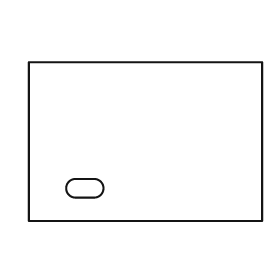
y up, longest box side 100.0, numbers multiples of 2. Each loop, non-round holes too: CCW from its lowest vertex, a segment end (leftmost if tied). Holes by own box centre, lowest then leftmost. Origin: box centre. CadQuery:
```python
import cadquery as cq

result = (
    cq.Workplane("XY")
    .moveTo(-50.0, -34.0)
    .lineTo(50.0, -34.0)
    .lineTo(50.0, 34.0)
    .lineTo(-50.0, 34.0)
    .close()
    .moveTo(-30.0, -24.0)
    .lineTo(-22.0, -24.0)
    .threePointArc((-18.0, -20.0), (-22.0, -16.0))
    .lineTo(-30.0, -16.0)
    .threePointArc((-34.0, -20.0), (-30.0, -24.0))
    .close()
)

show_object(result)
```